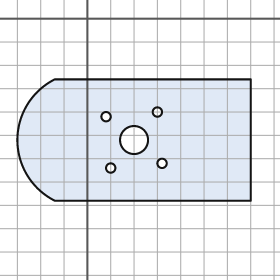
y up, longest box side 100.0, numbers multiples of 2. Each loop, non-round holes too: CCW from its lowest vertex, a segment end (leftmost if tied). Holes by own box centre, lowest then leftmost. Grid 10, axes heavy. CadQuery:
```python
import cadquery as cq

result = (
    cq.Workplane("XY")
    .moveTo(-14.0, -78.0)
    .lineTo(70.0, -78.0)
    .lineTo(70.0, -26.0)
    .lineTo(-14.0, -26.0)
    .threePointArc((-30.0, -52.0), (-14.0, -78.0))
    .close()
    .moveTo(10.0, -64.0)
    .circle(2.0)
    .moveTo(32.0, -62.0)
    .circle(2.0)
    .moveTo(20.0, -52.0)
    .circle(6.0)
    .moveTo(8.0, -42.0)
    .circle(2.0)
    .moveTo(30.0, -40.0)
    .circle(2.0)
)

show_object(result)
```